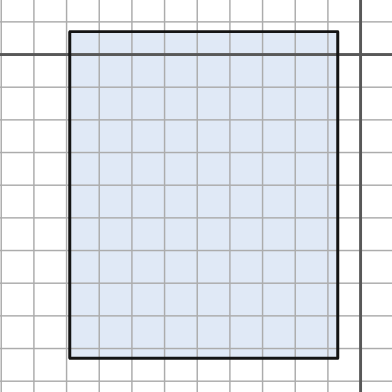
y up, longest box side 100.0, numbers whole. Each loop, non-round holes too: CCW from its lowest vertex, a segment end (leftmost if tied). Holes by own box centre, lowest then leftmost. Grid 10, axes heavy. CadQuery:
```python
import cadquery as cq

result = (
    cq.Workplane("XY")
    .moveTo(-89.0, -93.0)
    .lineTo(-7.0, -93.0)
    .lineTo(-7.0, 7.0)
    .lineTo(-89.0, 7.0)
    .close()
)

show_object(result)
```